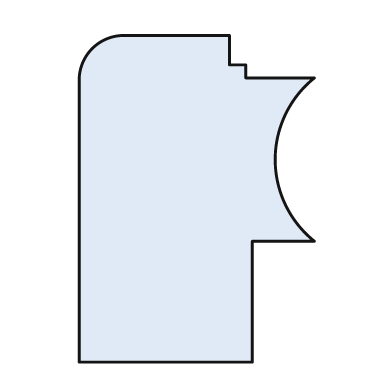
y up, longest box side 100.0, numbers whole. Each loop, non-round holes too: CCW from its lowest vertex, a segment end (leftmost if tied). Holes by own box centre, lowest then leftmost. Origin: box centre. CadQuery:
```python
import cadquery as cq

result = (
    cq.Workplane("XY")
    .moveTo(-36.0, -50.0)
    .lineTo(17.0, -50.0)
    .lineTo(17.0, -13.0)
    .lineTo(36.0, -13.0)
    .threePointArc((24.0, 12.0), (36.0, 37.0))
    .lineTo(15.0, 37.0)
    .lineTo(15.0, 41.0)
    .lineTo(10.0, 41.0)
    .lineTo(10.0, 50.0)
    .lineTo(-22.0, 50.0)
    .threePointArc((-32.0, 46.0), (-36.0, 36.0))
    .close()
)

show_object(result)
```